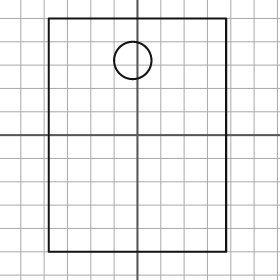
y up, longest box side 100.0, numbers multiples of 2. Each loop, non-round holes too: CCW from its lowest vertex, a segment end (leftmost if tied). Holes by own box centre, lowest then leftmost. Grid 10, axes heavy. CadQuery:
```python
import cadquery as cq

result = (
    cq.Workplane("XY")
    .moveTo(-38.0, -50.0)
    .lineTo(38.0, -50.0)
    .lineTo(38.0, 50.0)
    .lineTo(-38.0, 50.0)
    .close()
    .moveTo(-2.0, 32.0)
    .circle(8.0)
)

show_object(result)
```